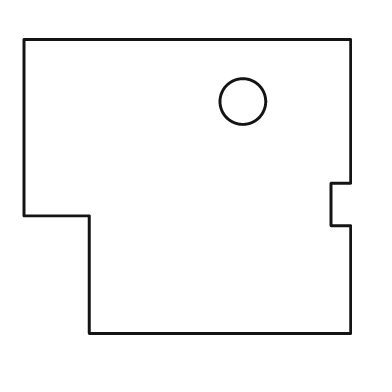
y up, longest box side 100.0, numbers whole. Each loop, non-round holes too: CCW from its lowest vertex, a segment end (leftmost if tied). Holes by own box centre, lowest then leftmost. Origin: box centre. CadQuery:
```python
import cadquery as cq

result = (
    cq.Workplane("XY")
    .moveTo(-30.0, -45.0)
    .lineTo(50.0, -45.0)
    .lineTo(50.0, -12.0)
    .lineTo(44.0, -12.0)
    .lineTo(44.0, 1.0)
    .lineTo(50.0, 1.0)
    .lineTo(50.0, 45.0)
    .lineTo(-50.0, 45.0)
    .lineTo(-50.0, -9.0)
    .lineTo(-30.0, -9.0)
    .close()
    .moveTo(17.0, 26.0)
    .circle(7.0)
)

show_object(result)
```